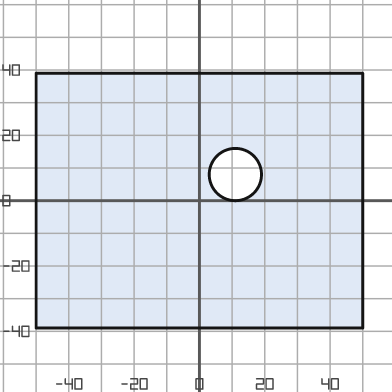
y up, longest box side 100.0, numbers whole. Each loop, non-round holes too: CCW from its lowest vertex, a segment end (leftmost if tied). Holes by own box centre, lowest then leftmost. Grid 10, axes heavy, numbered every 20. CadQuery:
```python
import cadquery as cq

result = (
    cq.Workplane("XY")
    .moveTo(-50.0, -39.0)
    .lineTo(50.0, -39.0)
    .lineTo(50.0, 39.0)
    .lineTo(-50.0, 39.0)
    .close()
    .moveTo(11.0, 8.0)
    .circle(8.0)
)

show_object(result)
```